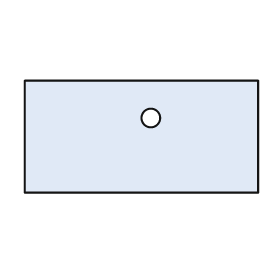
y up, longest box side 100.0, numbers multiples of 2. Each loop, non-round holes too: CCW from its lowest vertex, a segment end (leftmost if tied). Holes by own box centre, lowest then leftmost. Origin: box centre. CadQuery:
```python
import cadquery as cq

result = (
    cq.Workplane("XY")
    .moveTo(-50.0, -24.0)
    .lineTo(50.0, -24.0)
    .lineTo(50.0, 24.0)
    .lineTo(-50.0, 24.0)
    .close()
    .moveTo(4.0, 8.0)
    .circle(4.0)
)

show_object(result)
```